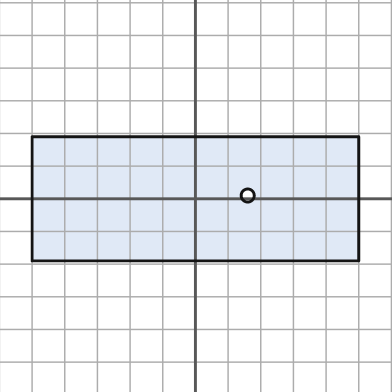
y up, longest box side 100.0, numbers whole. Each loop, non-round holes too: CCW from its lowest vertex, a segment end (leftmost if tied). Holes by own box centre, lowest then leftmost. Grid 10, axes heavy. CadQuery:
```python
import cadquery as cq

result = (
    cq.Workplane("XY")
    .moveTo(-50.0, -19.0)
    .lineTo(50.0, -19.0)
    .lineTo(50.0, 19.0)
    .lineTo(-50.0, 19.0)
    .close()
    .moveTo(16.0, 1.0)
    .circle(2.0)
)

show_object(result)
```